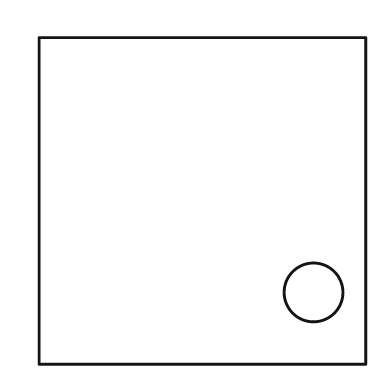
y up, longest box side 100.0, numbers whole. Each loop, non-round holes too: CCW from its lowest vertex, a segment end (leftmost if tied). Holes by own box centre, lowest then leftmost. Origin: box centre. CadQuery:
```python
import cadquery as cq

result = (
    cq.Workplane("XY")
    .moveTo(-50.0, -50.0)
    .lineTo(50.0, -50.0)
    .lineTo(50.0, 50.0)
    .lineTo(-50.0, 50.0)
    .close()
    .moveTo(34.0, -28.0)
    .circle(9.0)
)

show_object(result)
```